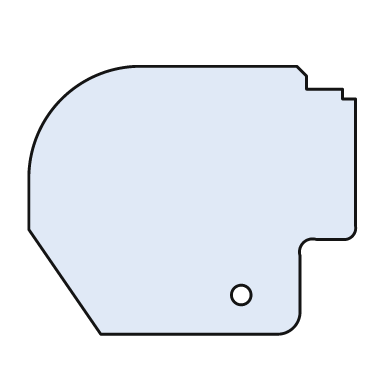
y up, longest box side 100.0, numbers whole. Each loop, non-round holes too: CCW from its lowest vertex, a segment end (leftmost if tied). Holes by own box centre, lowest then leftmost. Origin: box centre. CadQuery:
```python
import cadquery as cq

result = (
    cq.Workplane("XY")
    .moveTo(-28.0, -41.0)
    .lineTo(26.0, -41.0)
    .threePointArc((31.0, -39.0), (33.0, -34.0))
    .lineTo(33.0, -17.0)
    .threePointArc((34.0, -13.0), (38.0, -12.0))
    .lineTo(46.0, -12.0)
    .threePointArc((49.0, -11.0), (50.0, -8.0))
    .lineTo(50.0, 31.0)
    .lineTo(46.0, 31.0)
    .lineTo(46.0, 34.0)
    .lineTo(35.0, 34.0)
    .lineTo(35.0, 38.0)
    .lineTo(32.0, 41.0)
    .lineTo(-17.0, 41.0)
    .threePointArc((-40.0, 31.0), (-50.0, 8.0))
    .lineTo(-50.0, -9.0)
    .close()
    .moveTo(15.0, -29.0)
    .circle(3.0)
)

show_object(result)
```